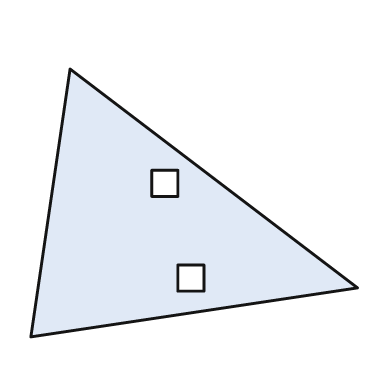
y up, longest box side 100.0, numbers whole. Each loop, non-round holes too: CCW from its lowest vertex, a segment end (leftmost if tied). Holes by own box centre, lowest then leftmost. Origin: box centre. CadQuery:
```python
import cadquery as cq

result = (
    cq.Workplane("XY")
    .moveTo(-50.0, -41.0)
    .lineTo(50.0, -26.0)
    .lineTo(-38.0, 41.0)
    .close()
    .moveTo(-5.0, -27.0)
    .lineTo(3.0, -27.0)
    .lineTo(3.0, -19.0)
    .lineTo(-5.0, -19.0)
    .close()
    .moveTo(-13.0, 2.0)
    .lineTo(-5.0, 2.0)
    .lineTo(-5.0, 10.0)
    .lineTo(-13.0, 10.0)
    .close()
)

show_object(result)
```